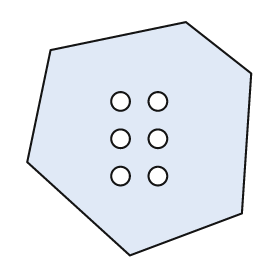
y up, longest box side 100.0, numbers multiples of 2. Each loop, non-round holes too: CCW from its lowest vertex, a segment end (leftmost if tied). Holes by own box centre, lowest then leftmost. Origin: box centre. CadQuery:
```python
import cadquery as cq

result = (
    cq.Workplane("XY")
    .moveTo(-4.0, -50.0)
    .lineTo(44.0, -32.0)
    .lineTo(48.0, 28.0)
    .lineTo(20.0, 50.0)
    .lineTo(-38.0, 38.0)
    .lineTo(-48.0, -10.0)
    .close()
    .moveTo(-8.0, -16.0)
    .circle(4.0)
    .moveTo(8.0, -16.0)
    .circle(4.0)
    .moveTo(-8.0, 0.0)
    .circle(4.0)
    .moveTo(8.0, 0.0)
    .circle(4.0)
    .moveTo(-8.0, 16.0)
    .circle(4.0)
    .moveTo(8.0, 16.0)
    .circle(4.0)
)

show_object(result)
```